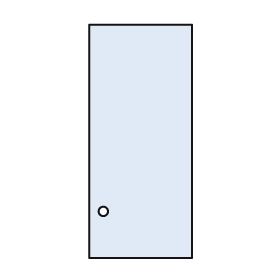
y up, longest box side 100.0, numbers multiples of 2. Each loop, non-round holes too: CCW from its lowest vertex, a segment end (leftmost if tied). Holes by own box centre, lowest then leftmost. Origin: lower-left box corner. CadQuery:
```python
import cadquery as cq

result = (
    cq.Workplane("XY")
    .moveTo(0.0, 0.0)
    .lineTo(44.0, 0.0)
    .lineTo(44.0, 100.0)
    .lineTo(0.0, 100.0)
    .close()
    .moveTo(6.0, 20.0)
    .circle(2.0)
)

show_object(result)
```